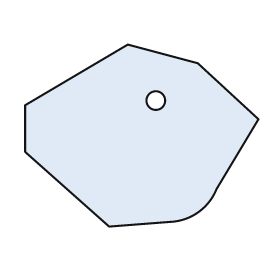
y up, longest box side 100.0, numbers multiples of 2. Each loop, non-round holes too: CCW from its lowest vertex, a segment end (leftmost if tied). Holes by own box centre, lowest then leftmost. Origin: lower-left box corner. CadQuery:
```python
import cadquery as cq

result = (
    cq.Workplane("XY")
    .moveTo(36.0, 0.0)
    .lineTo(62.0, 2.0)
    .threePointArc((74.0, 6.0), (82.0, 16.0))
    .lineTo(100.0, 46.0)
    .lineTo(74.0, 70.0)
    .lineTo(44.0, 78.0)
    .lineTo(0.0, 52.0)
    .lineTo(0.0, 32.0)
    .close()
    .moveTo(56.0, 54.0)
    .circle(4.0)
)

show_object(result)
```